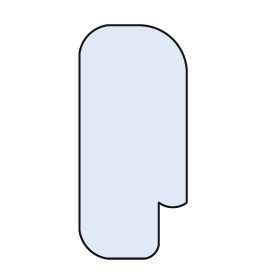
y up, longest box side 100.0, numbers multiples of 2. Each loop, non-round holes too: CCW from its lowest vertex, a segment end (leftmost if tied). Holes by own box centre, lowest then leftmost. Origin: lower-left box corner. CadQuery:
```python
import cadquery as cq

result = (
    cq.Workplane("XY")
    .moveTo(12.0, 0.0)
    .lineTo(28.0, 0.0)
    .threePointArc((32.0, 2.0), (34.0, 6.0))
    .lineTo(34.0, 24.0)
    .threePointArc((40.0, 22.0), (46.0, 24.0))
    .lineTo(46.0, 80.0)
    .threePointArc((40.0, 94.0), (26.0, 100.0))
    .lineTo(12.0, 100.0)
    .threePointArc((4.0, 96.0), (0.0, 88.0))
    .lineTo(0.0, 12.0)
    .threePointArc((4.0, 4.0), (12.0, 0.0))
    .close()
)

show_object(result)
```